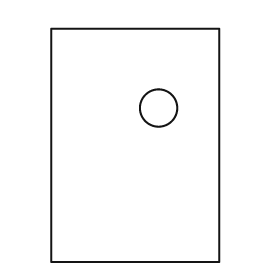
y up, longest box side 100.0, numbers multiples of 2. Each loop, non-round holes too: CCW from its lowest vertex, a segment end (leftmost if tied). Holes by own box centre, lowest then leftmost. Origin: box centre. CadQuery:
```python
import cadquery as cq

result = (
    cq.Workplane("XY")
    .moveTo(-36.0, -50.0)
    .lineTo(36.0, -50.0)
    .lineTo(36.0, 50.0)
    .lineTo(-36.0, 50.0)
    .close()
    .moveTo(10.0, 16.0)
    .circle(8.0)
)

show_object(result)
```